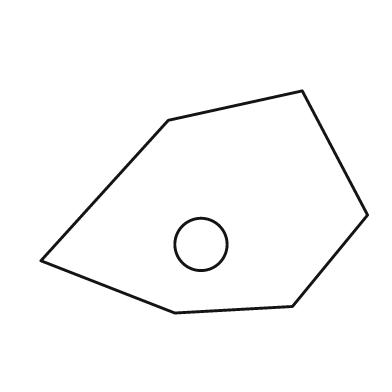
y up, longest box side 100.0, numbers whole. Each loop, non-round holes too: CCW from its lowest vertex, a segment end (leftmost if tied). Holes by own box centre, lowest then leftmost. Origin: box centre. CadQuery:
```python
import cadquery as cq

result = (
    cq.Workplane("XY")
    .moveTo(-9.0, -34.0)
    .lineTo(27.0, -32.0)
    .lineTo(50.0, -4.0)
    .lineTo(30.0, 34.0)
    .lineTo(-11.0, 25.0)
    .lineTo(-50.0, -18.0)
    .close()
    .moveTo(-1.0, -13.0)
    .circle(8.0)
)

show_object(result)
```